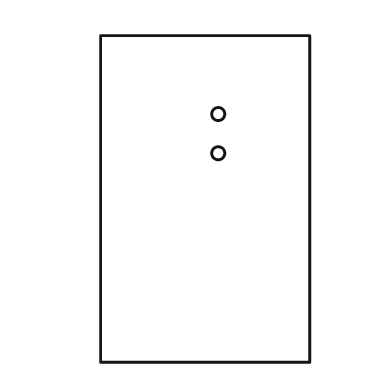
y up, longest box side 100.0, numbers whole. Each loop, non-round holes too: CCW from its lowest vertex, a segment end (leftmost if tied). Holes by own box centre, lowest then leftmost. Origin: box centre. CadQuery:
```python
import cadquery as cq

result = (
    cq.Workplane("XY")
    .moveTo(-32.0, -50.0)
    .lineTo(32.0, -50.0)
    .lineTo(32.0, 50.0)
    .lineTo(-32.0, 50.0)
    .close()
    .moveTo(4.0, 14.0)
    .circle(2.0)
    .moveTo(4.0, 26.0)
    .circle(2.0)
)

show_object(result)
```